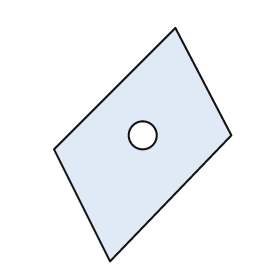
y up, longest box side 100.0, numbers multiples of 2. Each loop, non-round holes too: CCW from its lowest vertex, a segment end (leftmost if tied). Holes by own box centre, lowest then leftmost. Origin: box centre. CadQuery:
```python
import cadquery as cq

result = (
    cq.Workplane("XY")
    .moveTo(-14.0, -50.0)
    .lineTo(38.0, 4.0)
    .lineTo(14.0, 50.0)
    .lineTo(-38.0, -2.0)
    .close()
    .moveTo(0.0, 4.0)
    .circle(6.0)
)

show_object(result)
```